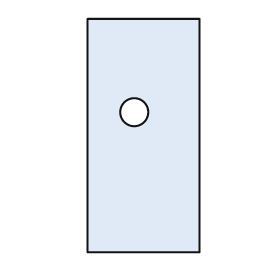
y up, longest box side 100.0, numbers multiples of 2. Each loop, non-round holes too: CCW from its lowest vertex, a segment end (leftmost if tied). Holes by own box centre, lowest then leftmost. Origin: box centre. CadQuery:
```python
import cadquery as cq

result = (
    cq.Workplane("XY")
    .moveTo(-24.0, -50.0)
    .lineTo(24.0, -50.0)
    .lineTo(24.0, 50.0)
    .lineTo(-24.0, 50.0)
    .close()
    .moveTo(-4.0, 10.0)
    .circle(6.0)
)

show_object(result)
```